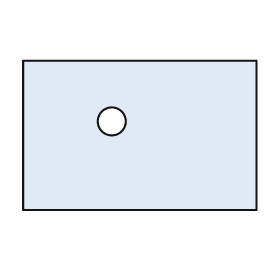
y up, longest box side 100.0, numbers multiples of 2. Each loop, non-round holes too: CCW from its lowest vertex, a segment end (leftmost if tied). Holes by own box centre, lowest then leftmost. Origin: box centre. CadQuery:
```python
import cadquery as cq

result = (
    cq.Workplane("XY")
    .moveTo(-50.0, -32.0)
    .lineTo(50.0, -32.0)
    .lineTo(50.0, 32.0)
    .lineTo(-50.0, 32.0)
    .close()
    .moveTo(-12.0, 6.0)
    .circle(6.0)
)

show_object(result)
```